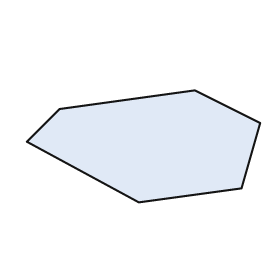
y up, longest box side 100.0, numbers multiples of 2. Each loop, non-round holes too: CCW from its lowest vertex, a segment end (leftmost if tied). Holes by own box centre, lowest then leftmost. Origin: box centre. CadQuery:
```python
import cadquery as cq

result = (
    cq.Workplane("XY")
    .moveTo(-2.0, -24.0)
    .lineTo(42.0, -18.0)
    .lineTo(50.0, 10.0)
    .lineTo(22.0, 24.0)
    .lineTo(-36.0, 16.0)
    .lineTo(-50.0, 2.0)
    .close()
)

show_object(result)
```